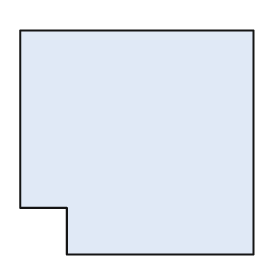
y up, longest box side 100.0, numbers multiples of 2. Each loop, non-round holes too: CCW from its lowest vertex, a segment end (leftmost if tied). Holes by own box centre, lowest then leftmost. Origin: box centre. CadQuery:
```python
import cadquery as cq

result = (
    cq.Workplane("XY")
    .moveTo(-30.0, -48.0)
    .lineTo(50.0, -48.0)
    .lineTo(50.0, 48.0)
    .lineTo(-50.0, 48.0)
    .lineTo(-50.0, -28.0)
    .lineTo(-30.0, -28.0)
    .close()
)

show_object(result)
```